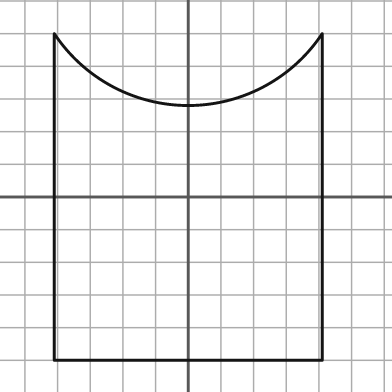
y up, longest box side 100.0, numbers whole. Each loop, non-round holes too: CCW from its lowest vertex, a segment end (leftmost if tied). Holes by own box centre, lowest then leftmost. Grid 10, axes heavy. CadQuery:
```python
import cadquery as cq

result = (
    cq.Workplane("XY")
    .moveTo(-41.0, -50.0)
    .lineTo(41.0, -50.0)
    .lineTo(41.0, 50.0)
    .threePointArc((0.0, 28.0), (-41.0, 50.0))
    .close()
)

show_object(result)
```